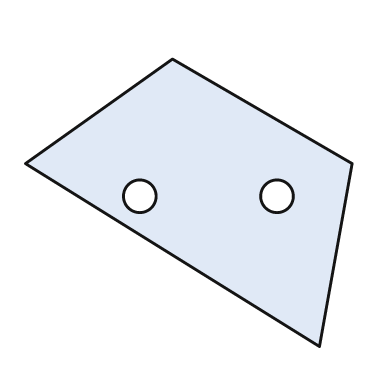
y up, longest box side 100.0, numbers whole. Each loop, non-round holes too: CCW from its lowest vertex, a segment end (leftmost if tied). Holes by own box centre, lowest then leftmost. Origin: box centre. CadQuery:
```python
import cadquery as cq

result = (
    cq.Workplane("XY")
    .moveTo(40.0, -44.0)
    .lineTo(50.0, 12.0)
    .lineTo(-5.0, 44.0)
    .lineTo(-50.0, 12.0)
    .close()
    .moveTo(-15.0, 2.0)
    .circle(5.0)
    .moveTo(27.0, 2.0)
    .circle(5.0)
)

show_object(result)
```